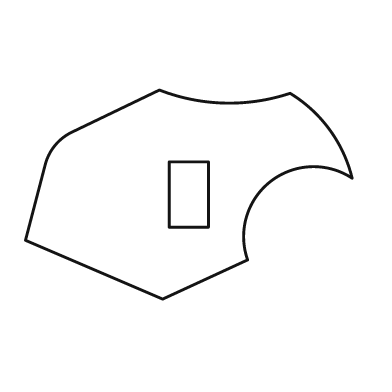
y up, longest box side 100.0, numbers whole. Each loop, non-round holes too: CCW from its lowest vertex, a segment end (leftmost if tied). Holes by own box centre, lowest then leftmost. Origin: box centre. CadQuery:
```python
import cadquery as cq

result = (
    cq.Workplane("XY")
    .moveTo(-8.0, -32.0)
    .lineTo(18.0, -20.0)
    .threePointArc((25.0, 4.0), (50.0, 5.0))
    .threePointArc((43.0, 20.0), (31.0, 31.0))
    .threePointArc((11.0, 28.0), (-9.0, 32.0))
    .lineTo(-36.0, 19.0)
    .threePointArc((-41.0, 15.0), (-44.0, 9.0))
    .lineTo(-50.0, -14.0)
    .close()
    .moveTo(-6.0, -10.0)
    .lineTo(6.0, -10.0)
    .lineTo(6.0, 10.0)
    .lineTo(-6.0, 10.0)
    .close()
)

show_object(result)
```